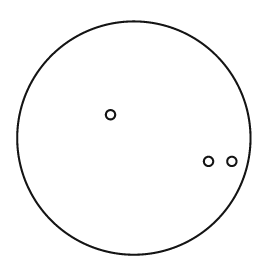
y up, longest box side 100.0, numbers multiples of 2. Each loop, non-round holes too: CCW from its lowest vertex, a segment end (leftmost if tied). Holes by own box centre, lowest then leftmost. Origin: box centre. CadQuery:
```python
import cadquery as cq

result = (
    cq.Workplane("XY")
    .moveTo(0.0, 0.0)
    .circle(50.0)
    .moveTo(32.0, -10.0)
    .circle(2.0)
    .moveTo(42.0, -10.0)
    .circle(2.0)
    .moveTo(-10.0, 10.0)
    .circle(2.0)
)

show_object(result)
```